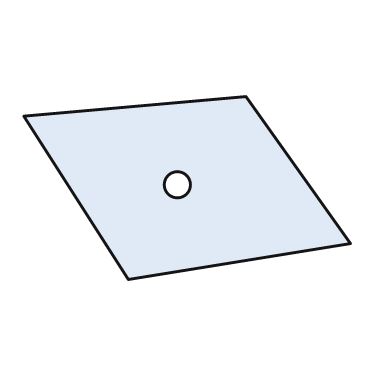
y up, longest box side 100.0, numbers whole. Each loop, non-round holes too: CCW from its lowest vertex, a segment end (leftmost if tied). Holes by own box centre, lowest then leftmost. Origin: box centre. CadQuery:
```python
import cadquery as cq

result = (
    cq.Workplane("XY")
    .moveTo(-18.0, -28.0)
    .lineTo(50.0, -17.0)
    .lineTo(18.0, 28.0)
    .lineTo(-50.0, 22.0)
    .close()
    .moveTo(-3.0, 1.0)
    .circle(4.0)
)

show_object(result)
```